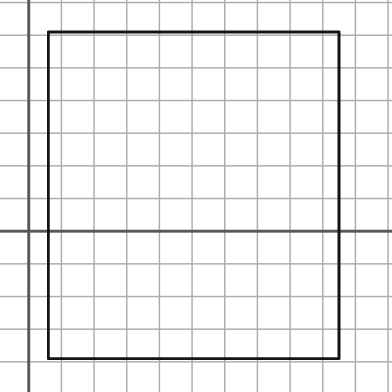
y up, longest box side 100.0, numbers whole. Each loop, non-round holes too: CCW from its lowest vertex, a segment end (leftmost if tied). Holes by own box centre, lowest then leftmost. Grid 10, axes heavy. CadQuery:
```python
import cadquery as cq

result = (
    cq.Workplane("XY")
    .moveTo(6.0, -39.0)
    .lineTo(95.0, -39.0)
    .lineTo(95.0, 61.0)
    .lineTo(6.0, 61.0)
    .close()
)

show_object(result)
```